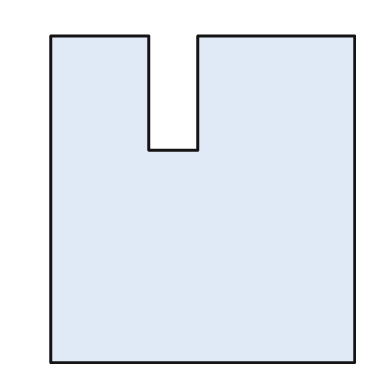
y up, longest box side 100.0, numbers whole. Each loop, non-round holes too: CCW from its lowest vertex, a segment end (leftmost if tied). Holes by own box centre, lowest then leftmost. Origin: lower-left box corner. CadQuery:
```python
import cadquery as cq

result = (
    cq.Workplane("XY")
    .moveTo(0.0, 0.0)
    .lineTo(93.0, 0.0)
    .lineTo(93.0, 100.0)
    .lineTo(45.0, 100.0)
    .lineTo(45.0, 65.0)
    .lineTo(30.0, 65.0)
    .lineTo(30.0, 100.0)
    .lineTo(0.0, 100.0)
    .close()
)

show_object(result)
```